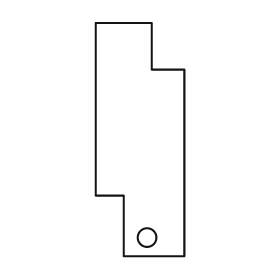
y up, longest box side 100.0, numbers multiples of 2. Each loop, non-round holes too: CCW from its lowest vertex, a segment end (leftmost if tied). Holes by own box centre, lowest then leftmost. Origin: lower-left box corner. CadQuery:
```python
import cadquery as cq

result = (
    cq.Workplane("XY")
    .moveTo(12.0, 0.0)
    .lineTo(38.0, 0.0)
    .lineTo(38.0, 80.0)
    .lineTo(24.0, 80.0)
    .lineTo(24.0, 100.0)
    .lineTo(0.0, 100.0)
    .lineTo(0.0, 26.0)
    .lineTo(12.0, 26.0)
    .close()
    .moveTo(22.0, 8.0)
    .circle(4.0)
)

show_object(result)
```